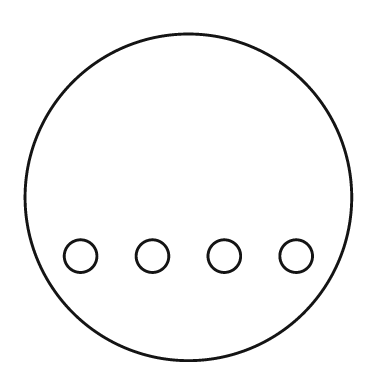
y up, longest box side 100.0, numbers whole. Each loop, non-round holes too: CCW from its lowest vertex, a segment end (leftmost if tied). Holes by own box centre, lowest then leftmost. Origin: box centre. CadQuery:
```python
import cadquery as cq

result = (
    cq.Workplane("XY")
    .moveTo(0.0, 0.0)
    .circle(50.0)
    .moveTo(-33.0, -18.0)
    .circle(5.0)
    .moveTo(-11.0, -18.0)
    .circle(5.0)
    .moveTo(11.0, -18.0)
    .circle(5.0)
    .moveTo(33.0, -18.0)
    .circle(5.0)
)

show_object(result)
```